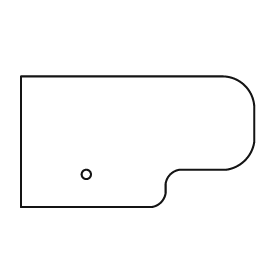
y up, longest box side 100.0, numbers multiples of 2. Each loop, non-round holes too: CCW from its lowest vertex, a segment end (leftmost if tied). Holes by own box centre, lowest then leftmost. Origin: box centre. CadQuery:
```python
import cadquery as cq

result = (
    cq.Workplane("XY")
    .moveTo(-50.0, -28.0)
    .lineTo(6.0, -28.0)
    .threePointArc((10.0, -26.0), (12.0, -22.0))
    .lineTo(12.0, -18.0)
    .threePointArc((14.0, -14.0), (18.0, -12.0))
    .lineTo(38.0, -12.0)
    .threePointArc((46.0, -8.0), (50.0, 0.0))
    .lineTo(50.0, 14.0)
    .threePointArc((46.0, 24.0), (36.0, 28.0))
    .lineTo(-50.0, 28.0)
    .close()
    .moveTo(-22.0, -14.0)
    .circle(2.0)
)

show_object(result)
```